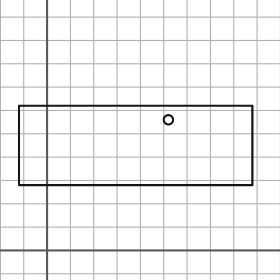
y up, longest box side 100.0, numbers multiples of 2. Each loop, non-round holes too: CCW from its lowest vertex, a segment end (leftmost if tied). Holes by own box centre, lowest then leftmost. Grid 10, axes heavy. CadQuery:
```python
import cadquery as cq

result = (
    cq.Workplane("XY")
    .moveTo(-12.0, 28.0)
    .lineTo(88.0, 28.0)
    .lineTo(88.0, 62.0)
    .lineTo(-12.0, 62.0)
    .close()
    .moveTo(52.0, 56.0)
    .circle(2.0)
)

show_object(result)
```